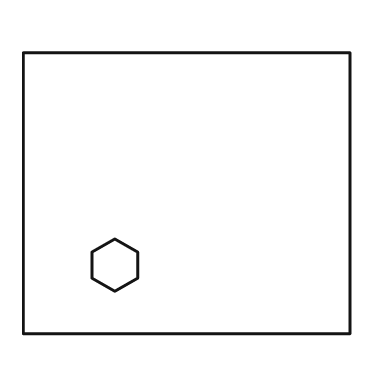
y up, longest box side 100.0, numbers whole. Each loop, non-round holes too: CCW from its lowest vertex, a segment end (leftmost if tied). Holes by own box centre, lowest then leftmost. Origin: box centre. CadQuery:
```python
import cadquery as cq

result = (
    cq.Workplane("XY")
    .moveTo(-50.0, -43.0)
    .lineTo(50.0, -43.0)
    .lineTo(50.0, 43.0)
    .lineTo(-50.0, 43.0)
    .close()
    .moveTo(-22.0, -30.0)
    .lineTo(-15.0, -26.0)
    .lineTo(-15.0, -18.0)
    .lineTo(-22.0, -14.0)
    .lineTo(-29.0, -18.0)
    .lineTo(-29.0, -26.0)
    .close()
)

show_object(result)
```